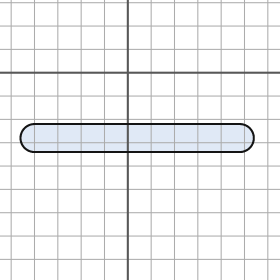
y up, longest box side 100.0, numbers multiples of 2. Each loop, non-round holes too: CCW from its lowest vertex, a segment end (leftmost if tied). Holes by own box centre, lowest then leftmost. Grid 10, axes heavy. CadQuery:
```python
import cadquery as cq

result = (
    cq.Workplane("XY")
    .moveTo(-40.0, -34.0)
    .lineTo(48.0, -34.0)
    .threePointArc((54.0, -28.0), (48.0, -22.0))
    .lineTo(-40.0, -22.0)
    .threePointArc((-46.0, -28.0), (-40.0, -34.0))
    .close()
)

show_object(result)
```